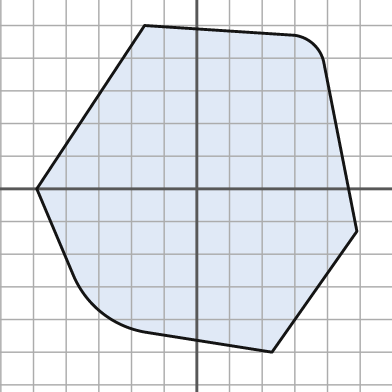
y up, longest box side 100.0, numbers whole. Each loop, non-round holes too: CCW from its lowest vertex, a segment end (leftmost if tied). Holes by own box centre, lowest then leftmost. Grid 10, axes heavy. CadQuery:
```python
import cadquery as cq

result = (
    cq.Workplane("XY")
    .moveTo(23.0, -50.0)
    .lineTo(49.0, -13.0)
    .lineTo(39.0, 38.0)
    .threePointArc((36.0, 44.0), (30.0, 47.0))
    .lineTo(-16.0, 50.0)
    .lineTo(-49.0, 0.0)
    .lineTo(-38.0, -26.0)
    .threePointArc((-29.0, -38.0), (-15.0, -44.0))
    .close()
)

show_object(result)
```